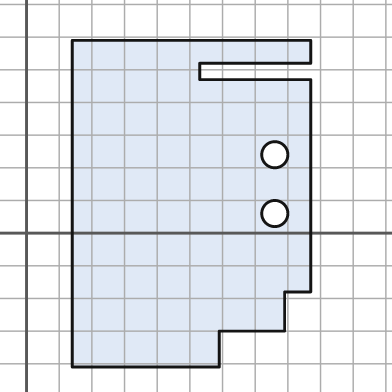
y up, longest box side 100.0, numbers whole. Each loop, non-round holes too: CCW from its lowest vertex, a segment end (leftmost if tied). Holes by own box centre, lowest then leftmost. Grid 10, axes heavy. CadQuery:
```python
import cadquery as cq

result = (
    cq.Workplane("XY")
    .moveTo(14.0, -41.0)
    .lineTo(59.0, -41.0)
    .lineTo(59.0, -30.0)
    .lineTo(79.0, -30.0)
    .lineTo(79.0, -18.0)
    .lineTo(87.0, -18.0)
    .lineTo(87.0, 47.0)
    .lineTo(53.0, 47.0)
    .lineTo(53.0, 52.0)
    .lineTo(87.0, 52.0)
    .lineTo(87.0, 59.0)
    .lineTo(14.0, 59.0)
    .close()
    .moveTo(76.0, 6.0)
    .circle(4.0)
    .moveTo(76.0, 24.0)
    .circle(4.0)
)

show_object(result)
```